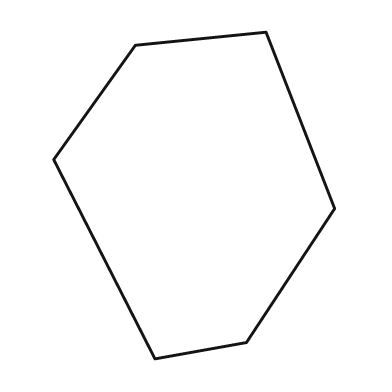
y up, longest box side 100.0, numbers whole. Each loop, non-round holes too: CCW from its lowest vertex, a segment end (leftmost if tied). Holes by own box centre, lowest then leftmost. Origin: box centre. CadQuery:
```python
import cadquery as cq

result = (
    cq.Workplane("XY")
    .moveTo(-12.0, -50.0)
    .lineTo(16.0, -45.0)
    .lineTo(43.0, -4.0)
    .lineTo(22.0, 50.0)
    .lineTo(-18.0, 46.0)
    .lineTo(-43.0, 11.0)
    .close()
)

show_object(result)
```